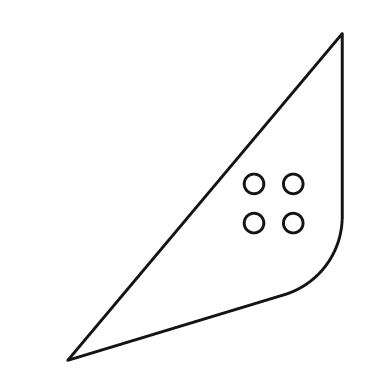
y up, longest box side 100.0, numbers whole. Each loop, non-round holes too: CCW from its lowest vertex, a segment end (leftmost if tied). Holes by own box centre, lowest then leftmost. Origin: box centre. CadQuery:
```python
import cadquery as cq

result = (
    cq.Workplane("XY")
    .moveTo(-42.0, -50.0)
    .lineTo(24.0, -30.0)
    .threePointArc((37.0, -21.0), (42.0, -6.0))
    .lineTo(42.0, 50.0)
    .close()
    .moveTo(15.0, -8.0)
    .circle(3.0)
    .moveTo(27.0, -8.0)
    .circle(3.0)
    .moveTo(15.0, 4.0)
    .circle(3.0)
    .moveTo(27.0, 4.0)
    .circle(3.0)
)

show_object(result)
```